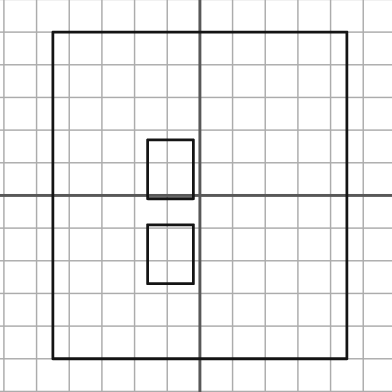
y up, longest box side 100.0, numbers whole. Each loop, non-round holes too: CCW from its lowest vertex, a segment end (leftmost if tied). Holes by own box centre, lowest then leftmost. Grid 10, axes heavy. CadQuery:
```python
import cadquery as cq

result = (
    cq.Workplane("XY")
    .moveTo(-45.0, -50.0)
    .lineTo(45.0, -50.0)
    .lineTo(45.0, 50.0)
    .lineTo(-45.0, 50.0)
    .close()
    .moveTo(-16.0, -27.0)
    .lineTo(-2.0, -27.0)
    .lineTo(-2.0, -9.0)
    .lineTo(-16.0, -9.0)
    .close()
    .moveTo(-16.0, -1.0)
    .lineTo(-2.0, -1.0)
    .lineTo(-2.0, 17.0)
    .lineTo(-16.0, 17.0)
    .close()
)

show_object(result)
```